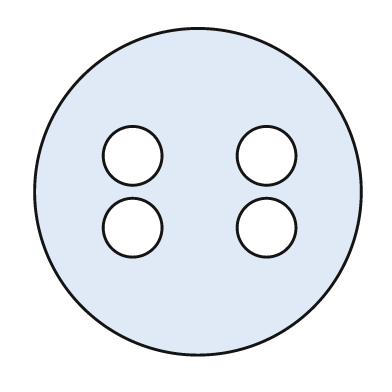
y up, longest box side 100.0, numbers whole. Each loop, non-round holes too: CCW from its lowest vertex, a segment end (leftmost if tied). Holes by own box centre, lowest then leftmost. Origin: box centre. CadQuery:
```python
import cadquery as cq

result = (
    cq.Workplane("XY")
    .moveTo(0.0, 0.0)
    .circle(50.0)
    .moveTo(-20.0, -11.0)
    .circle(9.0)
    .moveTo(21.0, -11.0)
    .circle(9.0)
    .moveTo(-20.0, 11.0)
    .circle(9.0)
    .moveTo(21.0, 11.0)
    .circle(9.0)
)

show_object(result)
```